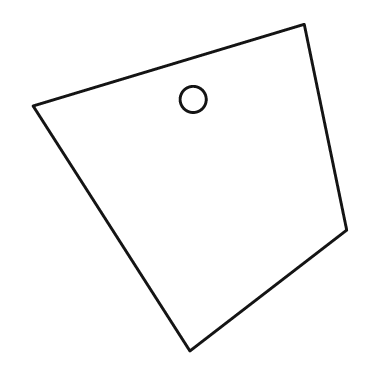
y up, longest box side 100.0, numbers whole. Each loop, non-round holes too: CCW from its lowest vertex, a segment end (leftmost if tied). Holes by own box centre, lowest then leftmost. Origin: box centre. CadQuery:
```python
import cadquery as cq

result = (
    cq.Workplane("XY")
    .moveTo(0.0, -50.0)
    .lineTo(48.0, -13.0)
    .lineTo(35.0, 50.0)
    .lineTo(-48.0, 25.0)
    .close()
    .moveTo(1.0, 27.0)
    .circle(4.0)
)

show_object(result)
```